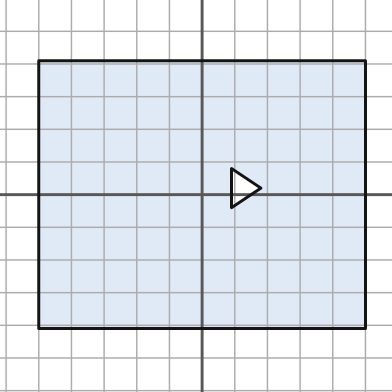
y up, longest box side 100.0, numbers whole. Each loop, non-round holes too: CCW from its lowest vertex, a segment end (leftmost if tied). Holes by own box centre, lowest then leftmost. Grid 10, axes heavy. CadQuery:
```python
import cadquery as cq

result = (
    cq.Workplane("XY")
    .moveTo(-50.0, -41.0)
    .lineTo(50.0, -41.0)
    .lineTo(50.0, 41.0)
    .lineTo(-50.0, 41.0)
    .close()
    .moveTo(9.0, -4.0)
    .lineTo(18.0, 2.0)
    .lineTo(9.0, 8.0)
    .close()
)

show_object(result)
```